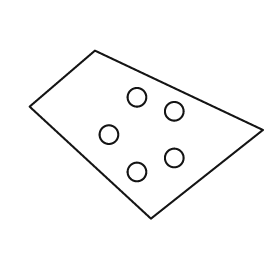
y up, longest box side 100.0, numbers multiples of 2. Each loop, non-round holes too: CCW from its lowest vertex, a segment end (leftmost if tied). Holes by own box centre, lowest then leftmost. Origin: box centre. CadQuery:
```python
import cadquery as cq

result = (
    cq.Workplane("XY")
    .moveTo(2.0, -36.0)
    .lineTo(50.0, 2.0)
    .lineTo(-22.0, 36.0)
    .lineTo(-50.0, 12.0)
    .close()
    .moveTo(-4.0, -16.0)
    .circle(4.0)
    .moveTo(12.0, -10.0)
    .circle(4.0)
    .moveTo(-16.0, 0.0)
    .circle(4.0)
    .moveTo(12.0, 10.0)
    .circle(4.0)
    .moveTo(-4.0, 16.0)
    .circle(4.0)
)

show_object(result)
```